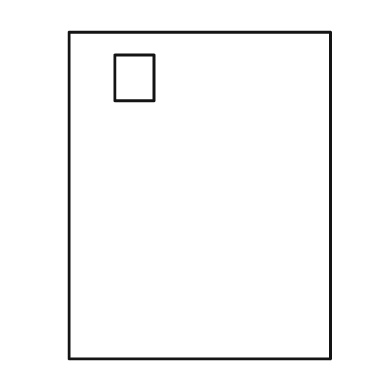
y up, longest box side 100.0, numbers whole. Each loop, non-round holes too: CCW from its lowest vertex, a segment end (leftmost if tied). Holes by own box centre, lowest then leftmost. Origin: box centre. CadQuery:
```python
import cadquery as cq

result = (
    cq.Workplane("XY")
    .moveTo(-40.0, -50.0)
    .lineTo(40.0, -50.0)
    .lineTo(40.0, 50.0)
    .lineTo(-40.0, 50.0)
    .close()
    .moveTo(-26.0, 29.0)
    .lineTo(-14.0, 29.0)
    .lineTo(-14.0, 43.0)
    .lineTo(-26.0, 43.0)
    .close()
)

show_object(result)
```